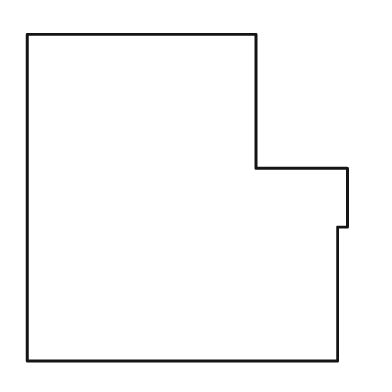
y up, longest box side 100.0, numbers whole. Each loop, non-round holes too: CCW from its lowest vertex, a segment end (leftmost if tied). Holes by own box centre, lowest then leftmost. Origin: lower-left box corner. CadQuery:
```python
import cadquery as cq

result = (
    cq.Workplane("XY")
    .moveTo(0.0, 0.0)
    .lineTo(95.0, 0.0)
    .lineTo(95.0, 41.0)
    .lineTo(98.0, 41.0)
    .lineTo(98.0, 59.0)
    .lineTo(70.0, 59.0)
    .lineTo(70.0, 100.0)
    .lineTo(0.0, 100.0)
    .close()
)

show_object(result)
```